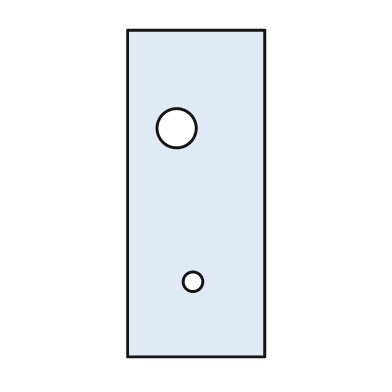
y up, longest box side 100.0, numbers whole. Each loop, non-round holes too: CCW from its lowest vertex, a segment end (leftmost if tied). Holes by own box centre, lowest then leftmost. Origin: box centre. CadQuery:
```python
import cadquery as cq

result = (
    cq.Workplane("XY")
    .moveTo(-21.0, -50.0)
    .lineTo(21.0, -50.0)
    .lineTo(21.0, 50.0)
    .lineTo(-21.0, 50.0)
    .close()
    .moveTo(-1.0, -27.0)
    .circle(3.0)
    .moveTo(-6.0, 20.0)
    .circle(6.0)
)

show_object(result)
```